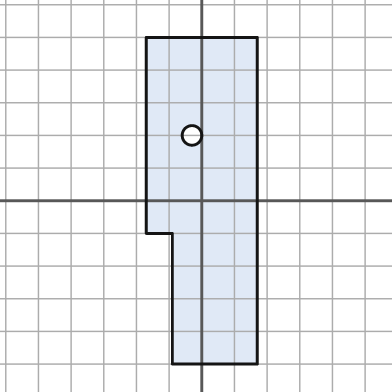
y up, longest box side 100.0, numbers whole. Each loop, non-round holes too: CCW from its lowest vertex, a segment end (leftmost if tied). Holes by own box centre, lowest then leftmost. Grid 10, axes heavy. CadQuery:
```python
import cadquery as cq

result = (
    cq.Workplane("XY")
    .moveTo(-9.0, -50.0)
    .lineTo(17.0, -50.0)
    .lineTo(17.0, 50.0)
    .lineTo(-17.0, 50.0)
    .lineTo(-17.0, -10.0)
    .lineTo(-9.0, -10.0)
    .close()
    .moveTo(-3.0, 20.0)
    .circle(3.0)
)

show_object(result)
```